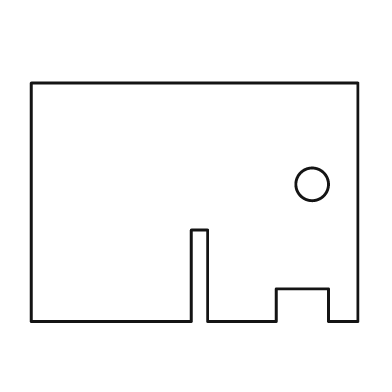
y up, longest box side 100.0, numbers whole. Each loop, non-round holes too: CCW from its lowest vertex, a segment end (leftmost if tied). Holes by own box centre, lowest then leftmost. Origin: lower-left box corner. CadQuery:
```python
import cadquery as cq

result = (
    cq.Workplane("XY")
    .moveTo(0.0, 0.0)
    .lineTo(49.0, 0.0)
    .lineTo(49.0, 28.0)
    .lineTo(54.0, 28.0)
    .lineTo(54.0, 0.0)
    .lineTo(75.0, 0.0)
    .lineTo(75.0, 10.0)
    .lineTo(91.0, 10.0)
    .lineTo(91.0, 0.0)
    .lineTo(100.0, 0.0)
    .lineTo(100.0, 73.0)
    .lineTo(0.0, 73.0)
    .close()
    .moveTo(86.0, 42.0)
    .circle(5.0)
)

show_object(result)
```